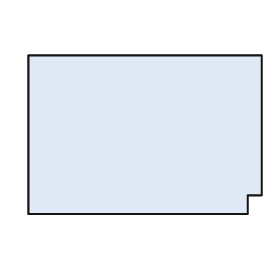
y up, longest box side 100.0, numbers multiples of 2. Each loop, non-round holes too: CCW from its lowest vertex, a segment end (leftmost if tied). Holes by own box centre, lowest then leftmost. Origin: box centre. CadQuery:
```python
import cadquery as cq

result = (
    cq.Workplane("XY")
    .moveTo(-50.0, -34.0)
    .lineTo(44.0, -34.0)
    .lineTo(44.0, -26.0)
    .lineTo(50.0, -26.0)
    .lineTo(50.0, 34.0)
    .lineTo(-50.0, 34.0)
    .close()
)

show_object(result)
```